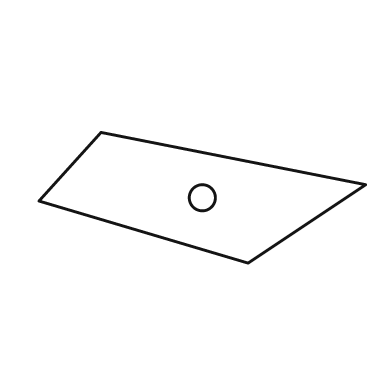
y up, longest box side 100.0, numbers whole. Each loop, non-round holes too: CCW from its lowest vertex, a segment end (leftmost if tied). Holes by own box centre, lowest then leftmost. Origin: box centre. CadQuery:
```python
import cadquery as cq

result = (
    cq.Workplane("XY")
    .moveTo(14.0, -20.0)
    .lineTo(50.0, 4.0)
    .lineTo(-31.0, 20.0)
    .lineTo(-50.0, -1.0)
    .close()
    .moveTo(0.0, 0.0)
    .circle(4.0)
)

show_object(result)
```